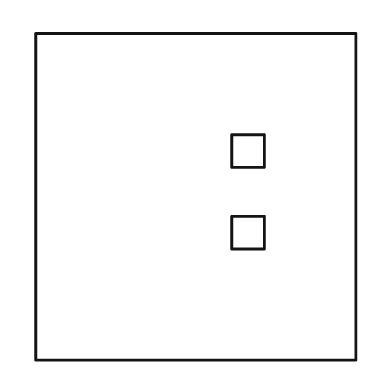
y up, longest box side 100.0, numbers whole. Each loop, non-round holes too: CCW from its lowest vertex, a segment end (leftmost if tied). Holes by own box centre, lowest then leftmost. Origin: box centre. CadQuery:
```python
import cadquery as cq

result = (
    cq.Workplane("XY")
    .moveTo(-49.0, -50.0)
    .lineTo(49.0, -50.0)
    .lineTo(49.0, 50.0)
    .lineTo(-49.0, 50.0)
    .close()
    .moveTo(11.0, -16.0)
    .lineTo(21.0, -16.0)
    .lineTo(21.0, -6.0)
    .lineTo(11.0, -6.0)
    .close()
    .moveTo(11.0, 9.0)
    .lineTo(21.0, 9.0)
    .lineTo(21.0, 19.0)
    .lineTo(11.0, 19.0)
    .close()
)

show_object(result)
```